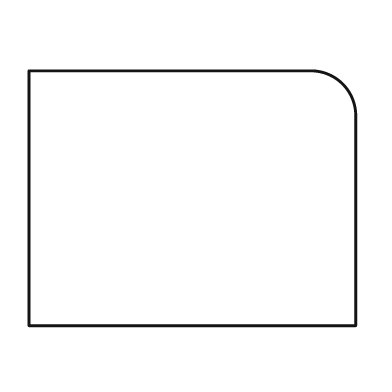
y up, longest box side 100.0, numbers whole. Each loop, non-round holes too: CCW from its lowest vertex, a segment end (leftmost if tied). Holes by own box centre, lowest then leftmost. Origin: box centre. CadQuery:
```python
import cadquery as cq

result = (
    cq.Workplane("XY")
    .moveTo(-50.0, -39.0)
    .lineTo(50.0, -39.0)
    .lineTo(50.0, 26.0)
    .threePointArc((46.0, 35.0), (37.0, 39.0))
    .lineTo(-50.0, 39.0)
    .close()
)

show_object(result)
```